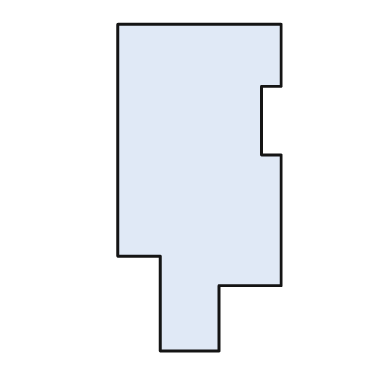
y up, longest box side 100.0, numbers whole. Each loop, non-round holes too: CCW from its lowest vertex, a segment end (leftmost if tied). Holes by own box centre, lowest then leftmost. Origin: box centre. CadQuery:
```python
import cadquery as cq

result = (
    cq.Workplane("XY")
    .moveTo(-12.0, -50.0)
    .lineTo(6.0, -50.0)
    .lineTo(6.0, -30.0)
    .lineTo(25.0, -30.0)
    .lineTo(25.0, 10.0)
    .lineTo(19.0, 10.0)
    .lineTo(19.0, 31.0)
    .lineTo(25.0, 31.0)
    .lineTo(25.0, 50.0)
    .lineTo(-25.0, 50.0)
    .lineTo(-25.0, -21.0)
    .lineTo(-12.0, -21.0)
    .close()
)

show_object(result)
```